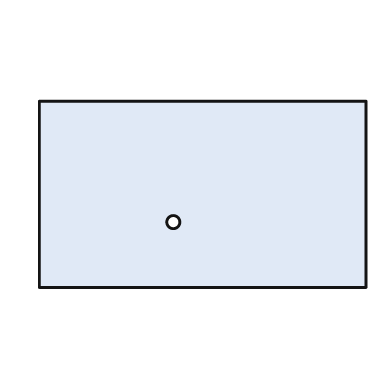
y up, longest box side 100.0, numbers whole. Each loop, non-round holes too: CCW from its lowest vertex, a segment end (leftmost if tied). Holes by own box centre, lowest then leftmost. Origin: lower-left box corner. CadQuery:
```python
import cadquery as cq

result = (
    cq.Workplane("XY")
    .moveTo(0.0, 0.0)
    .lineTo(100.0, 0.0)
    .lineTo(100.0, 57.0)
    .lineTo(0.0, 57.0)
    .close()
    .moveTo(41.0, 20.0)
    .circle(2.0)
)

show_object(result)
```